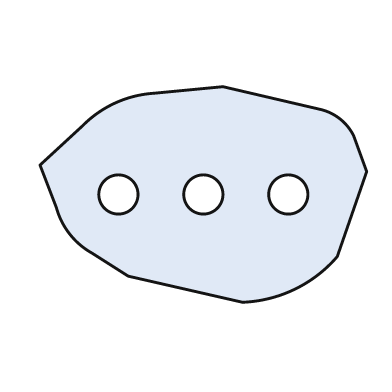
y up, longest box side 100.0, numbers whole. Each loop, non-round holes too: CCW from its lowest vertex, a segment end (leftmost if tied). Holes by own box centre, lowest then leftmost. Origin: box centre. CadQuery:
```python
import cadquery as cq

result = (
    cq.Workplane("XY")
    .moveTo(12.0, -33.0)
    .threePointArc((28.0, -29.0), (41.0, -19.0))
    .lineTo(50.0, 7.0)
    .lineTo(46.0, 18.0)
    .threePointArc((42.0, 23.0), (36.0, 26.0))
    .lineTo(6.0, 33.0)
    .lineTo(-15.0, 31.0)
    .threePointArc((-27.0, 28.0), (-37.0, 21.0))
    .lineTo(-50.0, 9.0)
    .lineTo(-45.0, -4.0)
    .threePointArc((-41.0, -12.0), (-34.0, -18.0))
    .lineTo(-23.0, -25.0)
    .close()
    .moveTo(-26.0, 0.0)
    .circle(6.0)
    .moveTo(0.0, 0.0)
    .circle(6.0)
    .moveTo(26.0, 0.0)
    .circle(6.0)
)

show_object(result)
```